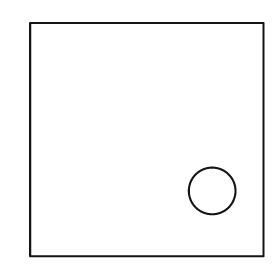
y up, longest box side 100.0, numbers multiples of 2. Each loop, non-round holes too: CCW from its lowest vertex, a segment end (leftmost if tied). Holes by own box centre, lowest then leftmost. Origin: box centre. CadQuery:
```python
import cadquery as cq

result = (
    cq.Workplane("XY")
    .moveTo(-50.0, -50.0)
    .lineTo(50.0, -50.0)
    .lineTo(50.0, 50.0)
    .lineTo(-50.0, 50.0)
    .close()
    .moveTo(28.0, -22.0)
    .circle(10.0)
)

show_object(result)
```